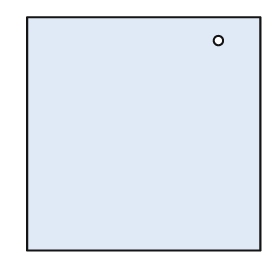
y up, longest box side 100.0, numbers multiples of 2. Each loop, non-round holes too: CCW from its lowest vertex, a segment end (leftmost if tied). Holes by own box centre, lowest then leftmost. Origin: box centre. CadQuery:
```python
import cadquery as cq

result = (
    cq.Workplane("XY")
    .moveTo(-50.0, -50.0)
    .lineTo(50.0, -50.0)
    .lineTo(50.0, 50.0)
    .lineTo(-50.0, 50.0)
    .close()
    .moveTo(32.0, 40.0)
    .circle(2.0)
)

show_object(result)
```